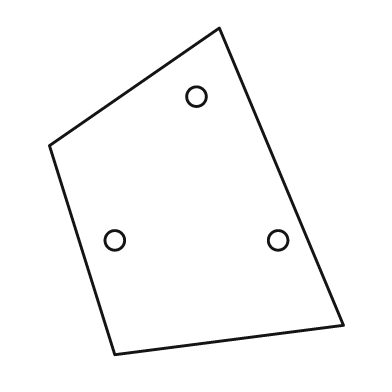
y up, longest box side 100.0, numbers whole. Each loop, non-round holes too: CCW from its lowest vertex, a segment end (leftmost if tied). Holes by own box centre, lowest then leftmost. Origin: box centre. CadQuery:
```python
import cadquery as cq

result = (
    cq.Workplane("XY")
    .moveTo(-25.0, -50.0)
    .lineTo(45.0, -41.0)
    .lineTo(7.0, 50.0)
    .lineTo(-45.0, 14.0)
    .close()
    .moveTo(-25.0, -15.0)
    .circle(3.0)
    .moveTo(25.0, -15.0)
    .circle(3.0)
    .moveTo(0.0, 29.0)
    .circle(3.0)
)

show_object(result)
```